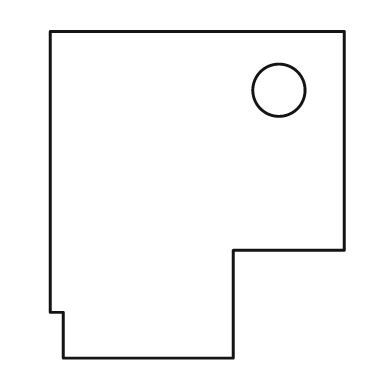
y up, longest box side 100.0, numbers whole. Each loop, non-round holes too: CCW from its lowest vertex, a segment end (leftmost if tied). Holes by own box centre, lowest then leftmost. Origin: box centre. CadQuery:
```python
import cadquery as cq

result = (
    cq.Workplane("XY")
    .moveTo(-41.0, -50.0)
    .lineTo(11.0, -50.0)
    .lineTo(11.0, -17.0)
    .lineTo(45.0, -17.0)
    .lineTo(45.0, 50.0)
    .lineTo(-45.0, 50.0)
    .lineTo(-45.0, -36.0)
    .lineTo(-41.0, -36.0)
    .close()
    .moveTo(25.0, 32.0)
    .circle(8.0)
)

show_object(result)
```